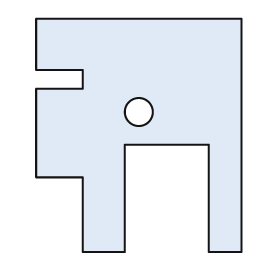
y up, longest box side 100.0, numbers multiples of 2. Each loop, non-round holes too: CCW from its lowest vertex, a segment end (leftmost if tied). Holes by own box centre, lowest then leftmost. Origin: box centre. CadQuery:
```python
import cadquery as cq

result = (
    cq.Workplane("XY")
    .moveTo(-24.0, -50.0)
    .lineTo(-6.0, -50.0)
    .lineTo(-6.0, -4.0)
    .lineTo(30.0, -4.0)
    .lineTo(30.0, -50.0)
    .lineTo(44.0, -50.0)
    .lineTo(44.0, 50.0)
    .lineTo(-44.0, 50.0)
    .lineTo(-44.0, 28.0)
    .lineTo(-24.0, 28.0)
    .lineTo(-24.0, 20.0)
    .lineTo(-44.0, 20.0)
    .lineTo(-44.0, -18.0)
    .lineTo(-24.0, -18.0)
    .close()
    .moveTo(0.0, 10.0)
    .circle(6.0)
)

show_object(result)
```